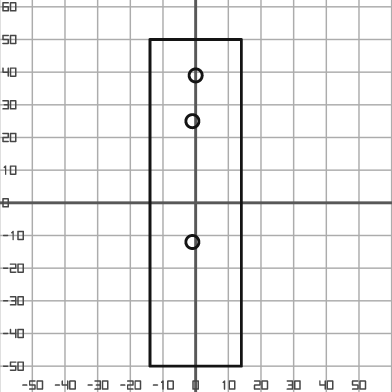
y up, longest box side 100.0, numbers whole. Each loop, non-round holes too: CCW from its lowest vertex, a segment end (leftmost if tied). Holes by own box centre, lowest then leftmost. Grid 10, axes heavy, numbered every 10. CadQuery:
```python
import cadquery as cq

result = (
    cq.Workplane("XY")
    .moveTo(-14.0, -50.0)
    .lineTo(14.0, -50.0)
    .lineTo(14.0, 50.0)
    .lineTo(-14.0, 50.0)
    .close()
    .moveTo(-1.0, -12.0)
    .circle(2.0)
    .moveTo(-1.0, 25.0)
    .circle(2.0)
    .moveTo(0.0, 39.0)
    .circle(2.0)
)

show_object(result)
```